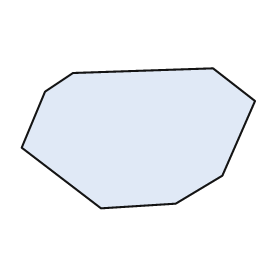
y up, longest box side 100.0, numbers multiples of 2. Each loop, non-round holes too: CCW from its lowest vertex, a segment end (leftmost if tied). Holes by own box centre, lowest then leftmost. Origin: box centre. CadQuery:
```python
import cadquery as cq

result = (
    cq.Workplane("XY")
    .moveTo(-16.0, -30.0)
    .lineTo(16.0, -28.0)
    .lineTo(36.0, -16.0)
    .lineTo(50.0, 16.0)
    .lineTo(32.0, 30.0)
    .lineTo(-28.0, 28.0)
    .lineTo(-40.0, 20.0)
    .lineTo(-50.0, -4.0)
    .close()
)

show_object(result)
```